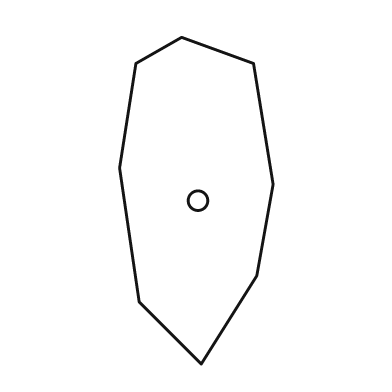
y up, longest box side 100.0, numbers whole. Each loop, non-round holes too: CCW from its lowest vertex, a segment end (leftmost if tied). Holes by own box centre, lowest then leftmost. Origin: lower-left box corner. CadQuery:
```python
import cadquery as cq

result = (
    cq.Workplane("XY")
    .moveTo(25.0, 0.0)
    .lineTo(42.0, 27.0)
    .lineTo(47.0, 55.0)
    .lineTo(41.0, 92.0)
    .lineTo(19.0, 100.0)
    .lineTo(5.0, 92.0)
    .lineTo(0.0, 60.0)
    .lineTo(6.0, 19.0)
    .close()
    .moveTo(24.0, 50.0)
    .circle(3.0)
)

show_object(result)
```